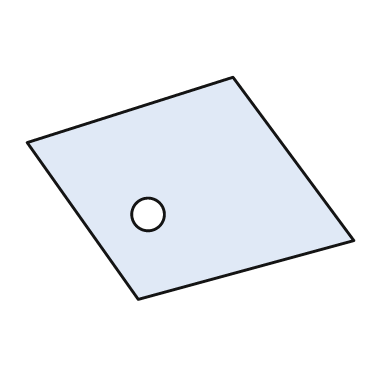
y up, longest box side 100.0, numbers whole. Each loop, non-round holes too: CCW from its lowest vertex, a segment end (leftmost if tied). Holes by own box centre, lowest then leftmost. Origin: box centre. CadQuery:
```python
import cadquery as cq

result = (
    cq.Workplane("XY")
    .moveTo(-16.0, -34.0)
    .lineTo(50.0, -16.0)
    .lineTo(13.0, 34.0)
    .lineTo(-50.0, 14.0)
    .close()
    .moveTo(-13.0, -8.0)
    .circle(5.0)
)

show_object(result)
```